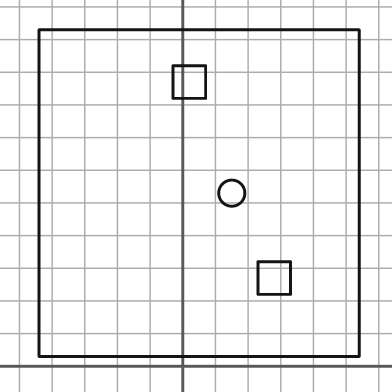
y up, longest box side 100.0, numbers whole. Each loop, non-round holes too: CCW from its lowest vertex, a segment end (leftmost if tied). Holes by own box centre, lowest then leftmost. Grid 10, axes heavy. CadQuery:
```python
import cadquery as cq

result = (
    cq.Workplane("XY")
    .moveTo(-44.0, 3.0)
    .lineTo(54.0, 3.0)
    .lineTo(54.0, 103.0)
    .lineTo(-44.0, 103.0)
    .close()
    .moveTo(23.0, 22.0)
    .lineTo(33.0, 22.0)
    .lineTo(33.0, 32.0)
    .lineTo(23.0, 32.0)
    .close()
    .moveTo(15.0, 53.0)
    .circle(4.0)
    .moveTo(-3.0, 82.0)
    .lineTo(7.0, 82.0)
    .lineTo(7.0, 92.0)
    .lineTo(-3.0, 92.0)
    .close()
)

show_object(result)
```